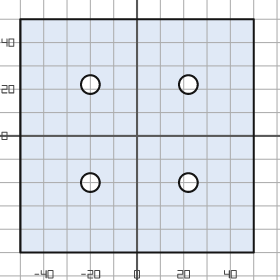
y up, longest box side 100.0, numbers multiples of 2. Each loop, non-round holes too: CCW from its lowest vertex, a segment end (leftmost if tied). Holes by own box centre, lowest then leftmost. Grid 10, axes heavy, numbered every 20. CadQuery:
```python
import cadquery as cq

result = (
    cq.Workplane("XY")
    .moveTo(-50.0, -50.0)
    .lineTo(50.0, -50.0)
    .lineTo(50.0, 50.0)
    .lineTo(-50.0, 50.0)
    .close()
    .moveTo(-20.0, -20.0)
    .circle(4.0)
    .moveTo(22.0, -20.0)
    .circle(4.0)
    .moveTo(-20.0, 22.0)
    .circle(4.0)
    .moveTo(22.0, 22.0)
    .circle(4.0)
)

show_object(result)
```